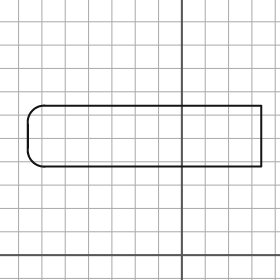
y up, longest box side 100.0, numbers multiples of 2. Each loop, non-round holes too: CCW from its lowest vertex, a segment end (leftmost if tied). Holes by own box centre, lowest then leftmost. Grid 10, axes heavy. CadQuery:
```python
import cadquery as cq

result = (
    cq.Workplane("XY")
    .moveTo(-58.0, 38.0)
    .lineTo(34.0, 38.0)
    .lineTo(34.0, 64.0)
    .lineTo(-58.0, 64.0)
    .threePointArc((-64.0, 62.0), (-66.0, 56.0))
    .lineTo(-66.0, 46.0)
    .threePointArc((-64.0, 40.0), (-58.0, 38.0))
    .close()
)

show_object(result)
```